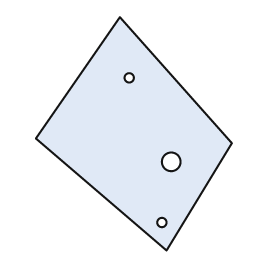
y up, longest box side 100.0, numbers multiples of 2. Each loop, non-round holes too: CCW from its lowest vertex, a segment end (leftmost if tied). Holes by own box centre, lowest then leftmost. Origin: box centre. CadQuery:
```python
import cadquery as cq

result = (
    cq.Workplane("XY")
    .moveTo(14.0, -50.0)
    .lineTo(42.0, -4.0)
    .lineTo(-6.0, 50.0)
    .lineTo(-42.0, -2.0)
    .close()
    .moveTo(12.0, -38.0)
    .circle(2.0)
    .moveTo(16.0, -12.0)
    .circle(4.0)
    .moveTo(-2.0, 24.0)
    .circle(2.0)
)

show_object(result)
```